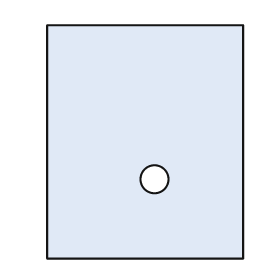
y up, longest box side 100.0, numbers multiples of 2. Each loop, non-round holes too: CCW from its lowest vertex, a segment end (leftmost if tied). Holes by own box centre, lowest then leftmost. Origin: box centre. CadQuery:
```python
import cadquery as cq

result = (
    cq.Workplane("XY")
    .moveTo(-42.0, -50.0)
    .lineTo(42.0, -50.0)
    .lineTo(42.0, 50.0)
    .lineTo(-42.0, 50.0)
    .close()
    .moveTo(4.0, -16.0)
    .circle(6.0)
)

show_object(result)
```